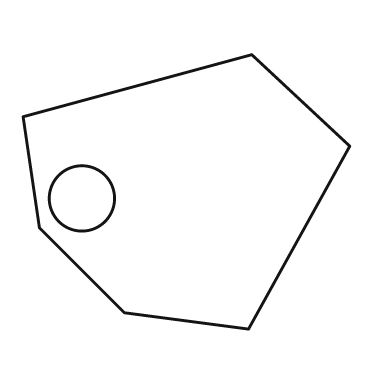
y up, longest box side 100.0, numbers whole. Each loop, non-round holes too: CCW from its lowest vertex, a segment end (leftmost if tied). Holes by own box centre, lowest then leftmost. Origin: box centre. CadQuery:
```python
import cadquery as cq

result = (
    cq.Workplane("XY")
    .moveTo(19.0, -42.0)
    .lineTo(50.0, 14.0)
    .lineTo(20.0, 42.0)
    .lineTo(-50.0, 23.0)
    .lineTo(-45.0, -11.0)
    .lineTo(-19.0, -37.0)
    .close()
    .moveTo(-32.0, -2.0)
    .circle(10.0)
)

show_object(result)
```